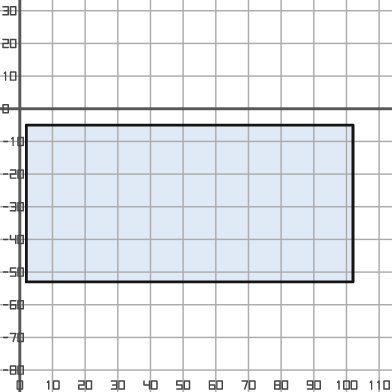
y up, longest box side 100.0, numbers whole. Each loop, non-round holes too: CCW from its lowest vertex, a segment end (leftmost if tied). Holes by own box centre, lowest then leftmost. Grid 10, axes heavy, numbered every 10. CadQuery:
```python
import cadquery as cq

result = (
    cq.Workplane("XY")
    .moveTo(2.0, -53.0)
    .lineTo(102.0, -53.0)
    .lineTo(102.0, -5.0)
    .lineTo(2.0, -5.0)
    .close()
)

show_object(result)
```